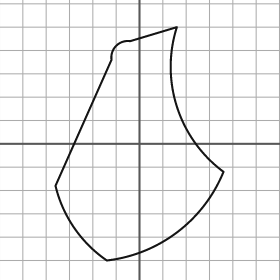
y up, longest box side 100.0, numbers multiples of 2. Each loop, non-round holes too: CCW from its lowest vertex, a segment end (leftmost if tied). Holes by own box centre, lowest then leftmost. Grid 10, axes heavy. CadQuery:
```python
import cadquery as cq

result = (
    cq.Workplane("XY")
    .moveTo(-14.0, -50.0)
    .threePointArc((16.0, -38.0), (36.0, -12.0))
    .threePointArc((16.0, 16.0), (16.0, 50.0))
    .lineTo(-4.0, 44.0)
    .threePointArc((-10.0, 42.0), (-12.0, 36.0))
    .lineTo(-36.0, -18.0)
    .threePointArc((-28.0, -36.0), (-14.0, -50.0))
    .close()
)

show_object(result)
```